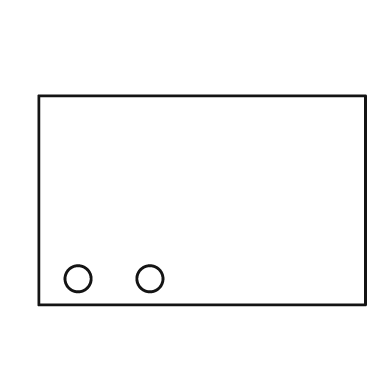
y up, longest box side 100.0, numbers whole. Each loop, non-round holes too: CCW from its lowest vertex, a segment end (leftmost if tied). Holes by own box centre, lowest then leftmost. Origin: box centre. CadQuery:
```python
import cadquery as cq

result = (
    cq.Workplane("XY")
    .moveTo(-50.0, -32.0)
    .lineTo(50.0, -32.0)
    .lineTo(50.0, 32.0)
    .lineTo(-50.0, 32.0)
    .close()
    .moveTo(-38.0, -24.0)
    .circle(4.0)
    .moveTo(-16.0, -24.0)
    .circle(4.0)
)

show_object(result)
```